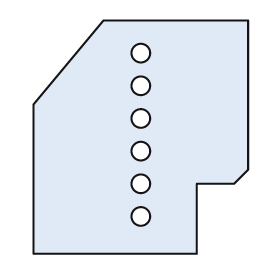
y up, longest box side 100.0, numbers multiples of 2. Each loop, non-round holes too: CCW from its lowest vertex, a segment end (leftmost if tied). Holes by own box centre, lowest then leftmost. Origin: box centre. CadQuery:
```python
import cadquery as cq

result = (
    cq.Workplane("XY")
    .moveTo(-46.0, -50.0)
    .lineTo(24.0, -50.0)
    .lineTo(24.0, -20.0)
    .lineTo(40.0, -20.0)
    .lineTo(46.0, -14.0)
    .lineTo(46.0, 50.0)
    .lineTo(-16.0, 50.0)
    .lineTo(-46.0, 14.0)
    .close()
    .moveTo(0.0, -34.0)
    .circle(4.0)
    .moveTo(0.0, -20.0)
    .circle(4.0)
    .moveTo(0.0, -6.0)
    .circle(4.0)
    .moveTo(0.0, 8.0)
    .circle(4.0)
    .moveTo(0.0, 22.0)
    .circle(4.0)
    .moveTo(0.0, 36.0)
    .circle(4.0)
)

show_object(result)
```